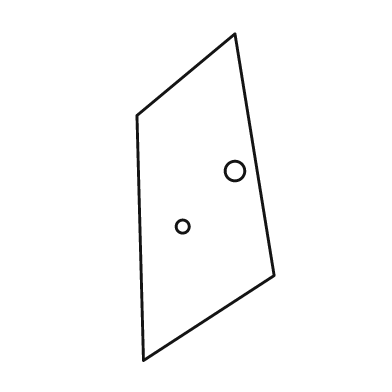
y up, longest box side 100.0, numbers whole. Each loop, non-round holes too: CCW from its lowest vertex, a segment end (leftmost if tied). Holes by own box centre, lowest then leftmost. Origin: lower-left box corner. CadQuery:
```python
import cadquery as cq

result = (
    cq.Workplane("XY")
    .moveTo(2.0, 0.0)
    .lineTo(42.0, 26.0)
    .lineTo(30.0, 100.0)
    .lineTo(0.0, 75.0)
    .close()
    .moveTo(14.0, 41.0)
    .circle(2.0)
    .moveTo(30.0, 58.0)
    .circle(3.0)
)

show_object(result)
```